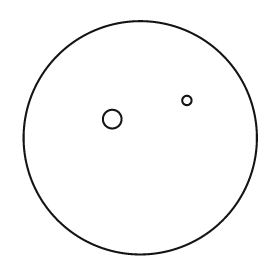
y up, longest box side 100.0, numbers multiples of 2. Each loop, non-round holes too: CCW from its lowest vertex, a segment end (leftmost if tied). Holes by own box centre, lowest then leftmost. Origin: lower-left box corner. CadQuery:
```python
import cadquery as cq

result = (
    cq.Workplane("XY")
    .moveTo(50.0, 50.0)
    .circle(50.0)
    .moveTo(38.0, 58.0)
    .circle(4.0)
    .moveTo(70.0, 66.0)
    .circle(2.0)
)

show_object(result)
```